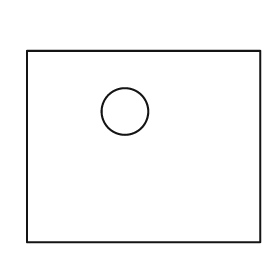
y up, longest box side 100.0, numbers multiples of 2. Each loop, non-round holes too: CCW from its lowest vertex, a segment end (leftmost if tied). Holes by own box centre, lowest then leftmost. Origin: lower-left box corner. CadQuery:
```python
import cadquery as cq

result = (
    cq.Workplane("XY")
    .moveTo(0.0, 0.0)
    .lineTo(100.0, 0.0)
    .lineTo(100.0, 82.0)
    .lineTo(0.0, 82.0)
    .close()
    .moveTo(42.0, 56.0)
    .circle(10.0)
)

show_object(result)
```